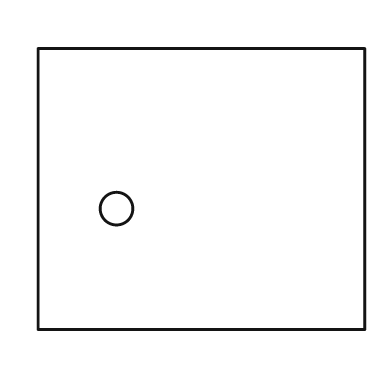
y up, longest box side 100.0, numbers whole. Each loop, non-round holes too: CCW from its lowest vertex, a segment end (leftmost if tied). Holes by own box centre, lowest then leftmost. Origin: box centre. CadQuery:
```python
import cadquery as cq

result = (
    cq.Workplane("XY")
    .moveTo(-50.0, -43.0)
    .lineTo(50.0, -43.0)
    .lineTo(50.0, 43.0)
    .lineTo(-50.0, 43.0)
    .close()
    .moveTo(-26.0, -6.0)
    .circle(5.0)
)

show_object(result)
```